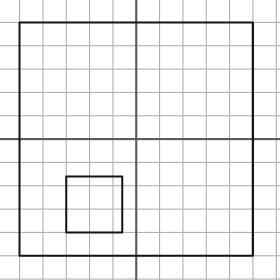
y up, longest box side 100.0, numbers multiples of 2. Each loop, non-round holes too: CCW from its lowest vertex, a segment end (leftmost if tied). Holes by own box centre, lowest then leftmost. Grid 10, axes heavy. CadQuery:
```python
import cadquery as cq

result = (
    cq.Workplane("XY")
    .moveTo(-50.0, -50.0)
    .lineTo(50.0, -50.0)
    .lineTo(50.0, 50.0)
    .lineTo(-50.0, 50.0)
    .close()
    .moveTo(-30.0, -40.0)
    .lineTo(-6.0, -40.0)
    .lineTo(-6.0, -16.0)
    .lineTo(-30.0, -16.0)
    .close()
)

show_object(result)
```